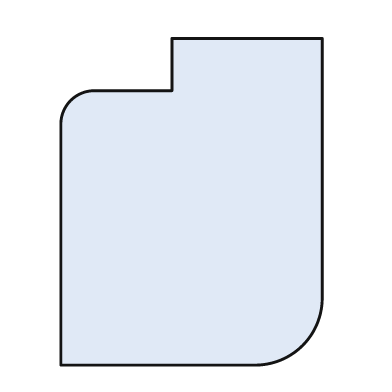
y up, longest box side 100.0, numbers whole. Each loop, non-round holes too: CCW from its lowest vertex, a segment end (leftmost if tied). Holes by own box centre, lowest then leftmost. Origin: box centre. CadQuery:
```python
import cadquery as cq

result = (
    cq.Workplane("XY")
    .moveTo(-40.0, -50.0)
    .lineTo(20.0, -50.0)
    .threePointArc((34.0, -44.0), (40.0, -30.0))
    .lineTo(40.0, 50.0)
    .lineTo(-6.0, 50.0)
    .lineTo(-6.0, 34.0)
    .lineTo(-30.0, 34.0)
    .threePointArc((-37.0, 31.0), (-40.0, 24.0))
    .close()
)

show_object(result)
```